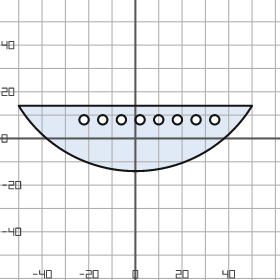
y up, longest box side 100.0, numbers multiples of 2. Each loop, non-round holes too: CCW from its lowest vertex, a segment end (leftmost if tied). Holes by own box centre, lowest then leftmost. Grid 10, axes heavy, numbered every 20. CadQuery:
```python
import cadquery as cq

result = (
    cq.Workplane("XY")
    .moveTo(-50.0, 14.0)
    .threePointArc((0.0, -14.0), (50.0, 14.0))
    .close()
    .moveTo(-22.0, 8.0)
    .circle(2.0)
    .moveTo(-14.0, 8.0)
    .circle(2.0)
    .moveTo(-6.0, 8.0)
    .circle(2.0)
    .moveTo(2.0, 8.0)
    .circle(2.0)
    .moveTo(10.0, 8.0)
    .circle(2.0)
    .moveTo(18.0, 8.0)
    .circle(2.0)
    .moveTo(26.0, 8.0)
    .circle(2.0)
    .moveTo(34.0, 8.0)
    .circle(2.0)
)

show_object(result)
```